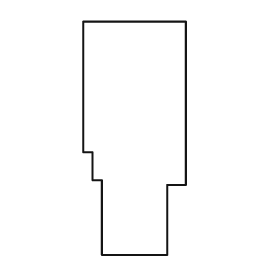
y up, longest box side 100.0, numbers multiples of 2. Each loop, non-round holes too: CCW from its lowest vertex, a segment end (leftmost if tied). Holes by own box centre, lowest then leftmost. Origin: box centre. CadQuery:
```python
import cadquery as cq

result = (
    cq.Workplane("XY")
    .moveTo(-14.0, -50.0)
    .lineTo(14.0, -50.0)
    .lineTo(14.0, -20.0)
    .lineTo(22.0, -20.0)
    .lineTo(22.0, 50.0)
    .lineTo(-22.0, 50.0)
    .lineTo(-22.0, -6.0)
    .lineTo(-18.0, -6.0)
    .lineTo(-18.0, -18.0)
    .lineTo(-14.0, -18.0)
    .close()
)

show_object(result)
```